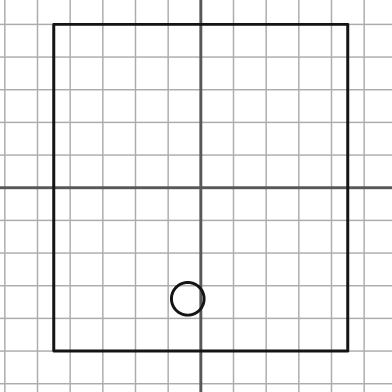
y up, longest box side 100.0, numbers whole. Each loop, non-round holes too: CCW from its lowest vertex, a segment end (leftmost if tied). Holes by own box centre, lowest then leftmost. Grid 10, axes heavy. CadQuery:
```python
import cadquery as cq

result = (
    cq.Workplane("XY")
    .moveTo(-45.0, -50.0)
    .lineTo(45.0, -50.0)
    .lineTo(45.0, 50.0)
    .lineTo(-45.0, 50.0)
    .close()
    .moveTo(-4.0, -34.0)
    .circle(5.0)
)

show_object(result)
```